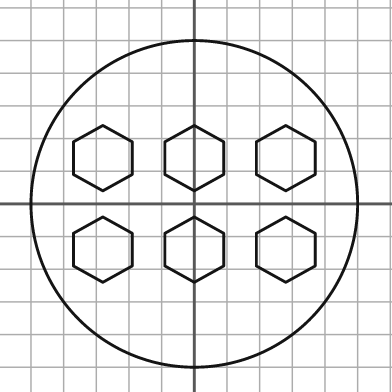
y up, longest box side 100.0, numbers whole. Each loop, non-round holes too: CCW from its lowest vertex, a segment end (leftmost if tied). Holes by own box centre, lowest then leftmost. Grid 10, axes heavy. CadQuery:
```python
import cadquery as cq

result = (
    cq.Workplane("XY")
    .moveTo(0.0, 0.0)
    .circle(50.0)
    .moveTo(-28.0, -24.0)
    .lineTo(-19.0, -19.0)
    .lineTo(-19.0, -9.0)
    .lineTo(-28.0, -4.0)
    .lineTo(-37.0, -9.0)
    .lineTo(-37.0, -19.0)
    .close()
    .moveTo(0.0, -24.0)
    .lineTo(9.0, -19.0)
    .lineTo(9.0, -9.0)
    .lineTo(0.0, -4.0)
    .lineTo(-9.0, -9.0)
    .lineTo(-9.0, -19.0)
    .close()
    .moveTo(28.0, -24.0)
    .lineTo(37.0, -19.0)
    .lineTo(37.0, -9.0)
    .lineTo(28.0, -4.0)
    .lineTo(19.0, -9.0)
    .lineTo(19.0, -19.0)
    .close()
    .moveTo(-28.0, 4.0)
    .lineTo(-19.0, 9.0)
    .lineTo(-19.0, 19.0)
    .lineTo(-28.0, 24.0)
    .lineTo(-37.0, 19.0)
    .lineTo(-37.0, 9.0)
    .close()
    .moveTo(0.0, 4.0)
    .lineTo(9.0, 9.0)
    .lineTo(9.0, 19.0)
    .lineTo(0.0, 24.0)
    .lineTo(-9.0, 19.0)
    .lineTo(-9.0, 9.0)
    .close()
    .moveTo(28.0, 4.0)
    .lineTo(37.0, 9.0)
    .lineTo(37.0, 19.0)
    .lineTo(28.0, 24.0)
    .lineTo(19.0, 19.0)
    .lineTo(19.0, 9.0)
    .close()
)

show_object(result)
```